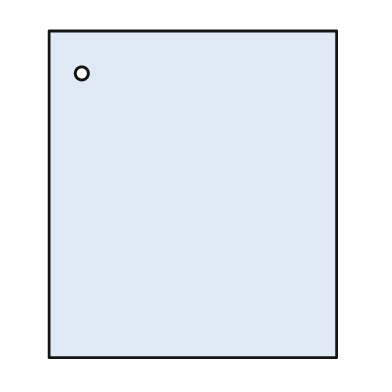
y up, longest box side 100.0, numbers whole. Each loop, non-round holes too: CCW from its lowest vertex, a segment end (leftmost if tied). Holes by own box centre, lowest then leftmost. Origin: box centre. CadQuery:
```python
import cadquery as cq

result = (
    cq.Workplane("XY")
    .moveTo(-44.0, -50.0)
    .lineTo(44.0, -50.0)
    .lineTo(44.0, 50.0)
    .lineTo(-44.0, 50.0)
    .close()
    .moveTo(-34.0, 37.0)
    .circle(2.0)
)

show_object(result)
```